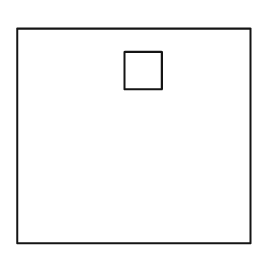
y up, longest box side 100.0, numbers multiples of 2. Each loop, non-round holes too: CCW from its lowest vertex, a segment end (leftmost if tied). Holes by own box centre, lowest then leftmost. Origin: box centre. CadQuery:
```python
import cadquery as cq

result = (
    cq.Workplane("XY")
    .moveTo(-50.0, -46.0)
    .lineTo(50.0, -46.0)
    .lineTo(50.0, 46.0)
    .lineTo(-50.0, 46.0)
    .close()
    .moveTo(-4.0, 20.0)
    .lineTo(12.0, 20.0)
    .lineTo(12.0, 36.0)
    .lineTo(-4.0, 36.0)
    .close()
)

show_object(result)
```